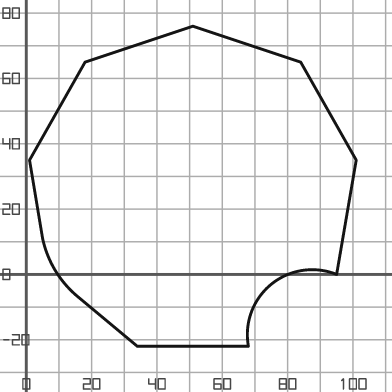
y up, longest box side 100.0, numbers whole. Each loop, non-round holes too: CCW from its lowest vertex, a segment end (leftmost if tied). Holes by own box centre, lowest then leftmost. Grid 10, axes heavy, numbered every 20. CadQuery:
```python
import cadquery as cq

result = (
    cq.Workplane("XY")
    .moveTo(34.0, -22.0)
    .lineTo(68.0, -22.0)
    .threePointArc((75.0, -3.0), (95.0, 0.0))
    .lineTo(101.0, 35.0)
    .lineTo(84.0, 65.0)
    .lineTo(51.0, 76.0)
    .lineTo(18.0, 65.0)
    .lineTo(1.0, 35.0)
    .lineTo(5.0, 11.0)
    .threePointArc((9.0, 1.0), (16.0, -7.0))
    .close()
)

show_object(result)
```